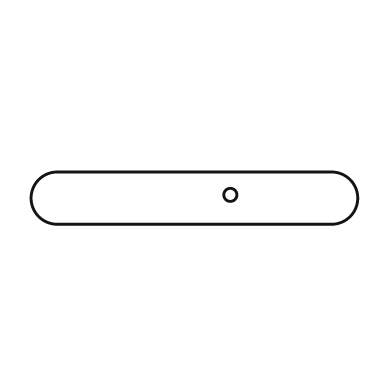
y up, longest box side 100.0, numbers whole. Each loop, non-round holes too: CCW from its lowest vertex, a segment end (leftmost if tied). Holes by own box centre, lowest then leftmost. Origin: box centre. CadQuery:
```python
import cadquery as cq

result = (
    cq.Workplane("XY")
    .moveTo(-42.0, -8.0)
    .lineTo(42.0, -8.0)
    .threePointArc((50.0, 0.0), (42.0, 8.0))
    .lineTo(-42.0, 8.0)
    .threePointArc((-50.0, 0.0), (-42.0, -8.0))
    .close()
    .moveTo(11.0, 1.0)
    .circle(2.0)
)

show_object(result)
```